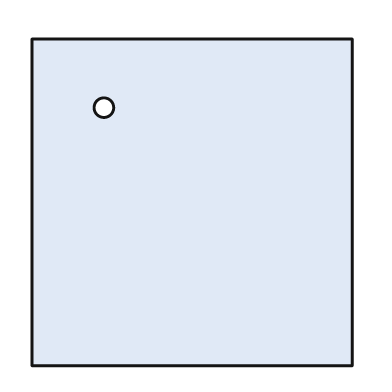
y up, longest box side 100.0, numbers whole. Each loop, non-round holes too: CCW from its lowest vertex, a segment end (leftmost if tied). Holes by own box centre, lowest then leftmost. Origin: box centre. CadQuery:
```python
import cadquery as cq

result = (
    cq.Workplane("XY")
    .moveTo(-49.0, -50.0)
    .lineTo(49.0, -50.0)
    .lineTo(49.0, 50.0)
    .lineTo(-49.0, 50.0)
    .close()
    .moveTo(-27.0, 29.0)
    .circle(3.0)
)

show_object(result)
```